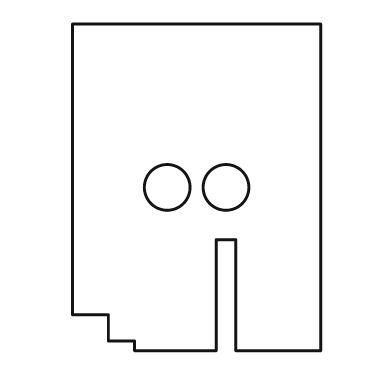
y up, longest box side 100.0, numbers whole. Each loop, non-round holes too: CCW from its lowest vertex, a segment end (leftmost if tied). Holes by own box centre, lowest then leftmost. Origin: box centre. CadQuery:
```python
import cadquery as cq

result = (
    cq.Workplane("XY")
    .moveTo(-19.0, -50.0)
    .lineTo(6.0, -50.0)
    .lineTo(6.0, -16.0)
    .lineTo(12.0, -16.0)
    .lineTo(12.0, -50.0)
    .lineTo(38.0, -50.0)
    .lineTo(38.0, 50.0)
    .lineTo(-38.0, 50.0)
    .lineTo(-38.0, -39.0)
    .lineTo(-27.0, -39.0)
    .lineTo(-27.0, -47.0)
    .lineTo(-19.0, -47.0)
    .close()
    .moveTo(-9.0, 0.0)
    .circle(7.0)
    .moveTo(9.0, 0.0)
    .circle(7.0)
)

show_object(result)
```